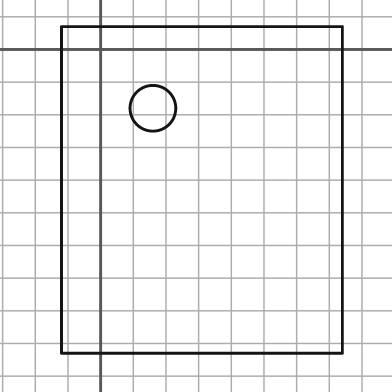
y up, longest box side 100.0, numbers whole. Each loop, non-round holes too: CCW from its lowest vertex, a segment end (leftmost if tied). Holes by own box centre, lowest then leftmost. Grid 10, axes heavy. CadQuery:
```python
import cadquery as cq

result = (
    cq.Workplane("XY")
    .moveTo(-12.0, -93.0)
    .lineTo(74.0, -93.0)
    .lineTo(74.0, 7.0)
    .lineTo(-12.0, 7.0)
    .close()
    .moveTo(16.0, -18.0)
    .circle(7.0)
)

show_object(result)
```